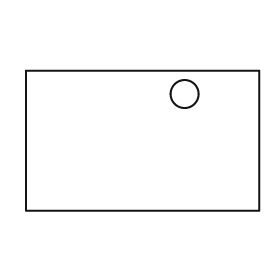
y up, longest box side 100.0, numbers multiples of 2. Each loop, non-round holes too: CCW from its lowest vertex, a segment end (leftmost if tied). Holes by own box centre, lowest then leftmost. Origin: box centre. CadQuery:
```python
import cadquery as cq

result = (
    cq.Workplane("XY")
    .moveTo(-50.0, -30.0)
    .lineTo(50.0, -30.0)
    .lineTo(50.0, 30.0)
    .lineTo(-50.0, 30.0)
    .close()
    .moveTo(18.0, 20.0)
    .circle(6.0)
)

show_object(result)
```